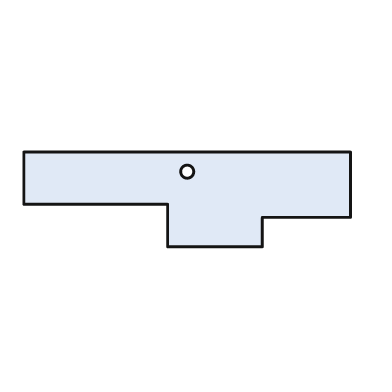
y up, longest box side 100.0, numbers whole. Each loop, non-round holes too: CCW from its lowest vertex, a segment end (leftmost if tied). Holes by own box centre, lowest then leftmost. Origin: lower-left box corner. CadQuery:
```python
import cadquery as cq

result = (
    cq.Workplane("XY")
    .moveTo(44.0, 0.0)
    .lineTo(73.0, 0.0)
    .lineTo(73.0, 9.0)
    .lineTo(100.0, 9.0)
    .lineTo(100.0, 29.0)
    .lineTo(0.0, 29.0)
    .lineTo(0.0, 13.0)
    .lineTo(44.0, 13.0)
    .close()
    .moveTo(50.0, 23.0)
    .circle(2.0)
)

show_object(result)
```